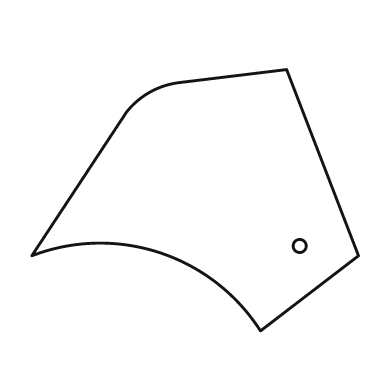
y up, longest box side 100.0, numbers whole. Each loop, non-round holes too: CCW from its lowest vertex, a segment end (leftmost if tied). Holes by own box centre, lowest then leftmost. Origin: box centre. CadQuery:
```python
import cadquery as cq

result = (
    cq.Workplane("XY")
    .moveTo(20.0, -40.0)
    .lineTo(50.0, -17.0)
    .lineTo(28.0, 40.0)
    .lineTo(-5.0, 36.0)
    .threePointArc((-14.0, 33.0), (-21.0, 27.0))
    .lineTo(-50.0, -17.0)
    .threePointArc((-11.0, -16.0), (20.0, -40.0))
    .close()
    .moveTo(32.0, -14.0)
    .circle(2.0)
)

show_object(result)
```